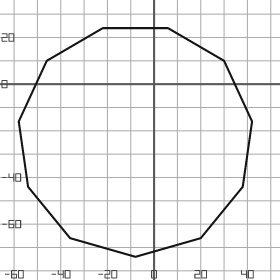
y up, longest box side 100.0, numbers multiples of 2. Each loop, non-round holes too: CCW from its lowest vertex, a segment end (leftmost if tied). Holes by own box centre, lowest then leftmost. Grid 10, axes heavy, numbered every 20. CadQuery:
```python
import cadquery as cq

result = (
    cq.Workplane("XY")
    .moveTo(-8.0, -74.0)
    .lineTo(20.0, -66.0)
    .lineTo(38.0, -44.0)
    .lineTo(42.0, -16.0)
    .lineTo(30.0, 10.0)
    .lineTo(6.0, 24.0)
    .lineTo(-22.0, 24.0)
    .lineTo(-46.0, 10.0)
    .lineTo(-58.0, -16.0)
    .lineTo(-54.0, -44.0)
    .lineTo(-36.0, -66.0)
    .close()
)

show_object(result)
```